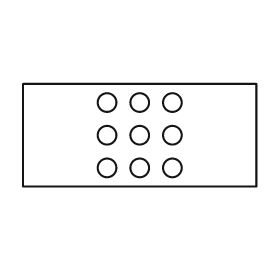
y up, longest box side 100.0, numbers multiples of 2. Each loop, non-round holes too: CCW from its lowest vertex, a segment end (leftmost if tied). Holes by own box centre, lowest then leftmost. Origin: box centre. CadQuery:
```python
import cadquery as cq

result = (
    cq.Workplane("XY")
    .moveTo(-50.0, -22.0)
    .lineTo(50.0, -22.0)
    .lineTo(50.0, 22.0)
    .lineTo(-50.0, 22.0)
    .close()
    .moveTo(-14.0, -14.0)
    .circle(4.0)
    .moveTo(0.0, -14.0)
    .circle(4.0)
    .moveTo(14.0, -14.0)
    .circle(4.0)
    .moveTo(-14.0, 0.0)
    .circle(4.0)
    .moveTo(0.0, 0.0)
    .circle(4.0)
    .moveTo(14.0, 0.0)
    .circle(4.0)
    .moveTo(-14.0, 14.0)
    .circle(4.0)
    .moveTo(0.0, 14.0)
    .circle(4.0)
    .moveTo(14.0, 14.0)
    .circle(4.0)
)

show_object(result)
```